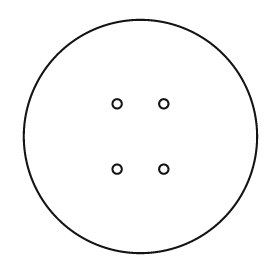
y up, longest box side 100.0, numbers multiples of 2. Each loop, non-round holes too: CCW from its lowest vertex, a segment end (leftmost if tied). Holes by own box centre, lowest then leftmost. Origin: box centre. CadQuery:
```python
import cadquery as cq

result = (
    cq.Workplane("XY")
    .moveTo(0.0, 0.0)
    .circle(50.0)
    .moveTo(-10.0, -14.0)
    .circle(2.0)
    .moveTo(10.0, -14.0)
    .circle(2.0)
    .moveTo(-10.0, 14.0)
    .circle(2.0)
    .moveTo(10.0, 14.0)
    .circle(2.0)
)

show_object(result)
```